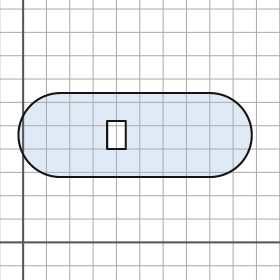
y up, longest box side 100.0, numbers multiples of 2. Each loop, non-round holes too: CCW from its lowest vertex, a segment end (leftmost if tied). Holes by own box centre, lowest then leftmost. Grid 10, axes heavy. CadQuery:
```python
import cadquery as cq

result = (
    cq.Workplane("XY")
    .moveTo(16.0, 28.0)
    .lineTo(80.0, 28.0)
    .threePointArc((98.0, 46.0), (80.0, 64.0))
    .lineTo(16.0, 64.0)
    .threePointArc((-2.0, 46.0), (16.0, 28.0))
    .close()
    .moveTo(36.0, 40.0)
    .lineTo(44.0, 40.0)
    .lineTo(44.0, 52.0)
    .lineTo(36.0, 52.0)
    .close()
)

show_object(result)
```